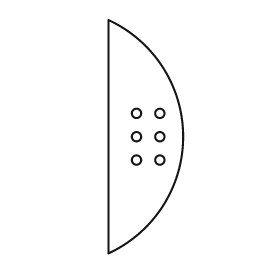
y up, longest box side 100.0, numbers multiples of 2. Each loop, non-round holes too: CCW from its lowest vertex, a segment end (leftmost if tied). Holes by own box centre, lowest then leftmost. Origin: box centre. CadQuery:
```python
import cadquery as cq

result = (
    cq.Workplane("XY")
    .moveTo(-16.0, -50.0)
    .threePointArc((16.0, 0.0), (-16.0, 50.0))
    .close()
    .moveTo(-4.0, -10.0)
    .circle(2.0)
    .moveTo(6.0, -10.0)
    .circle(2.0)
    .moveTo(-4.0, 0.0)
    .circle(2.0)
    .moveTo(6.0, 0.0)
    .circle(2.0)
    .moveTo(-4.0, 10.0)
    .circle(2.0)
    .moveTo(6.0, 10.0)
    .circle(2.0)
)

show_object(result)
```